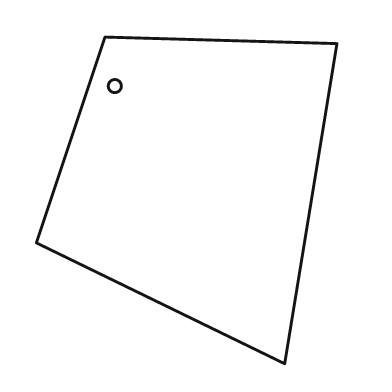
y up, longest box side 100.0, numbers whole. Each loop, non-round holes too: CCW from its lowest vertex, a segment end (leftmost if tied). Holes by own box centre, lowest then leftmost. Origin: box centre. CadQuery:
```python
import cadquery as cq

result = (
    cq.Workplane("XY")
    .moveTo(30.0, -50.0)
    .lineTo(46.0, 48.0)
    .lineTo(-25.0, 50.0)
    .lineTo(-46.0, -13.0)
    .close()
    .moveTo(-22.0, 35.0)
    .circle(2.0)
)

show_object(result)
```